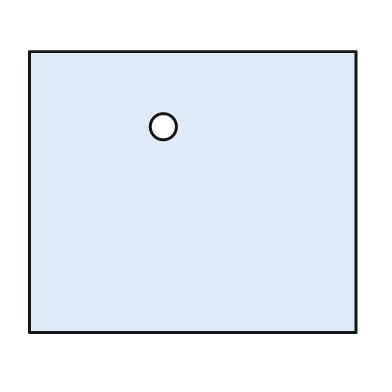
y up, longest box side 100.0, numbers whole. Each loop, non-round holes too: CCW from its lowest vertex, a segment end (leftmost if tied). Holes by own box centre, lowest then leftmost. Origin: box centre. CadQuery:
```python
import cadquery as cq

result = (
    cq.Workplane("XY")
    .moveTo(-50.0, -43.0)
    .lineTo(50.0, -43.0)
    .lineTo(50.0, 43.0)
    .lineTo(-50.0, 43.0)
    .close()
    .moveTo(-9.0, 20.0)
    .circle(4.0)
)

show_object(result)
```